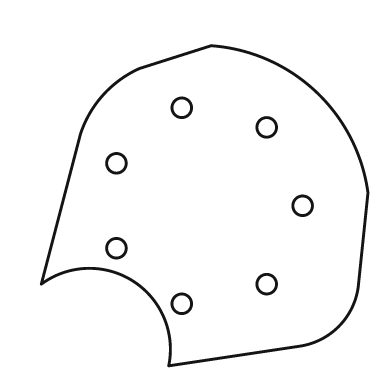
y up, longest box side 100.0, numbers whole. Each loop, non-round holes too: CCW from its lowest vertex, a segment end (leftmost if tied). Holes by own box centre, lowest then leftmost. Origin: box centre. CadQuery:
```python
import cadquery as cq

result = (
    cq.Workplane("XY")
    .moveTo(-11.0, -49.0)
    .lineTo(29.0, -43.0)
    .threePointArc((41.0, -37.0), (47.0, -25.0))
    .lineTo(50.0, 4.0)
    .threePointArc((34.0, 35.0), (2.0, 49.0))
    .lineTo(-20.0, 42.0)
    .threePointArc((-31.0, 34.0), (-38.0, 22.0))
    .lineTo(-50.0, -24.0)
    .threePointArc((-22.0, -23.0), (-11.0, -49.0))
    .close()
    .moveTo(-7.0, -30.0)
    .circle(3.0)
    .moveTo(19.0, -24.0)
    .circle(3.0)
    .moveTo(-27.0, -13.0)
    .circle(3.0)
    .moveTo(30.0, 0.0)
    .circle(3.0)
    .moveTo(-27.0, 13.0)
    .circle(3.0)
    .moveTo(19.0, 24.0)
    .circle(3.0)
    .moveTo(-7.0, 30.0)
    .circle(3.0)
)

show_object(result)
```